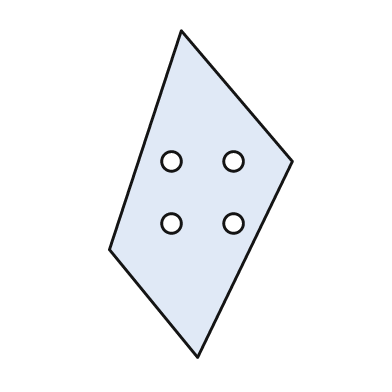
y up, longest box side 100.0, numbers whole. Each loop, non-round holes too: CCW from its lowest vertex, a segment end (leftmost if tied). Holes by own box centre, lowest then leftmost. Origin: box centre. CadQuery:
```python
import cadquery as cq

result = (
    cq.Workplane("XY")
    .moveTo(-1.0, -50.0)
    .lineTo(28.0, 10.0)
    .lineTo(-6.0, 50.0)
    .lineTo(-28.0, -17.0)
    .close()
    .moveTo(-9.0, -9.0)
    .circle(3.0)
    .moveTo(10.0, -9.0)
    .circle(3.0)
    .moveTo(-9.0, 10.0)
    .circle(3.0)
    .moveTo(10.0, 10.0)
    .circle(3.0)
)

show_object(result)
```